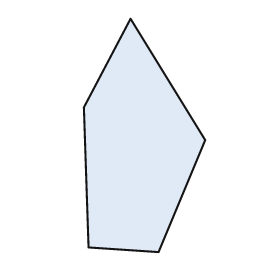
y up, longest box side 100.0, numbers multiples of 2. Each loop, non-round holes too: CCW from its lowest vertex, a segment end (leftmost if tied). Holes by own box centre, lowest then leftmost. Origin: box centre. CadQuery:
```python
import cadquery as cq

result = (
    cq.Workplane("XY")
    .moveTo(6.0, -50.0)
    .lineTo(26.0, -2.0)
    .lineTo(-6.0, 50.0)
    .lineTo(-26.0, 12.0)
    .lineTo(-24.0, -48.0)
    .close()
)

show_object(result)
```